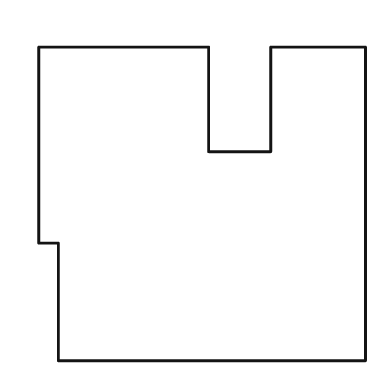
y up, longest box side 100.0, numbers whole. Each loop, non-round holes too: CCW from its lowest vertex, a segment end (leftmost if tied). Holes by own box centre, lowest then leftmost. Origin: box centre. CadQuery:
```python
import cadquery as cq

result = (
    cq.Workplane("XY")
    .moveTo(-44.0, -48.0)
    .lineTo(50.0, -48.0)
    .lineTo(50.0, 48.0)
    .lineTo(21.0, 48.0)
    .lineTo(21.0, 16.0)
    .lineTo(2.0, 16.0)
    .lineTo(2.0, 48.0)
    .lineTo(-50.0, 48.0)
    .lineTo(-50.0, -12.0)
    .lineTo(-44.0, -12.0)
    .close()
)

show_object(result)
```